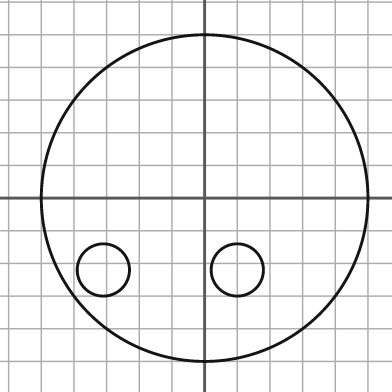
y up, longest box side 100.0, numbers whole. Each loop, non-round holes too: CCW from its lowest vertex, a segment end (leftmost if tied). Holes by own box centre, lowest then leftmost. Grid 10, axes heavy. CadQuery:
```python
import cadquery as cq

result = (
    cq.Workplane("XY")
    .moveTo(0.0, 0.0)
    .circle(50.0)
    .moveTo(-31.0, -22.0)
    .circle(8.0)
    .moveTo(10.0, -22.0)
    .circle(8.0)
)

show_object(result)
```